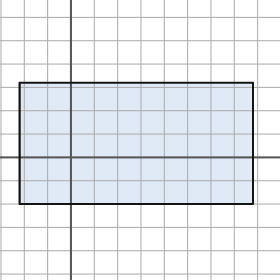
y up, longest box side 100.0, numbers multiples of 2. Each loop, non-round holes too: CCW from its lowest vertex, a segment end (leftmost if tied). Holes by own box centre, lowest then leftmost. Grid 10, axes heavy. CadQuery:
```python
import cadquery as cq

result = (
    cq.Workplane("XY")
    .moveTo(-22.0, -20.0)
    .lineTo(78.0, -20.0)
    .lineTo(78.0, 32.0)
    .lineTo(-22.0, 32.0)
    .close()
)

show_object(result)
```